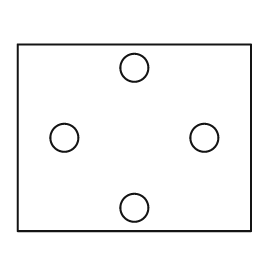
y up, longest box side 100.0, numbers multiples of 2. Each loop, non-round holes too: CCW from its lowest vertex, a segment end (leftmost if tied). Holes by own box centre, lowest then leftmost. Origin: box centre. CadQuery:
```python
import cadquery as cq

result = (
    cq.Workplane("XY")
    .moveTo(-50.0, -40.0)
    .lineTo(50.0, -40.0)
    .lineTo(50.0, 40.0)
    .lineTo(-50.0, 40.0)
    .close()
    .moveTo(0.0, -30.0)
    .circle(6.0)
    .moveTo(-30.0, 0.0)
    .circle(6.0)
    .moveTo(30.0, 0.0)
    .circle(6.0)
    .moveTo(0.0, 30.0)
    .circle(6.0)
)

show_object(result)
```